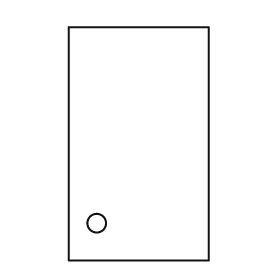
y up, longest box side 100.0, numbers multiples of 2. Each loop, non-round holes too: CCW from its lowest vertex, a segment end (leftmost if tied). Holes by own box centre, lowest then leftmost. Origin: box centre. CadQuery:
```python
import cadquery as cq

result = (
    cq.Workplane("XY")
    .moveTo(-30.0, -50.0)
    .lineTo(30.0, -50.0)
    .lineTo(30.0, 50.0)
    .lineTo(-30.0, 50.0)
    .close()
    .moveTo(-18.0, -34.0)
    .circle(4.0)
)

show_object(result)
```